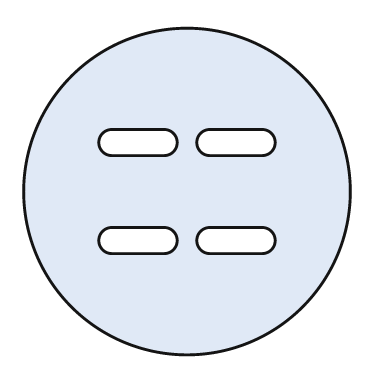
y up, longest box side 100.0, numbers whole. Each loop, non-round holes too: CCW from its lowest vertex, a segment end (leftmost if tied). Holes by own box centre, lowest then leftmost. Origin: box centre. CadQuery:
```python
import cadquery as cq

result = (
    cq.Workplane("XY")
    .moveTo(0.0, 0.0)
    .circle(50.0)
    .moveTo(-23.0, -19.0)
    .lineTo(-7.0, -19.0)
    .threePointArc((-3.0, -15.0), (-7.0, -11.0))
    .lineTo(-23.0, -11.0)
    .threePointArc((-27.0, -15.0), (-23.0, -19.0))
    .close()
    .moveTo(7.0, -19.0)
    .lineTo(23.0, -19.0)
    .threePointArc((27.0, -15.0), (23.0, -11.0))
    .lineTo(7.0, -11.0)
    .threePointArc((3.0, -15.0), (7.0, -19.0))
    .close()
    .moveTo(-23.0, 11.0)
    .lineTo(-7.0, 11.0)
    .threePointArc((-3.0, 15.0), (-7.0, 19.0))
    .lineTo(-23.0, 19.0)
    .threePointArc((-27.0, 15.0), (-23.0, 11.0))
    .close()
    .moveTo(7.0, 11.0)
    .lineTo(23.0, 11.0)
    .threePointArc((27.0, 15.0), (23.0, 19.0))
    .lineTo(7.0, 19.0)
    .threePointArc((3.0, 15.0), (7.0, 11.0))
    .close()
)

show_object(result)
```